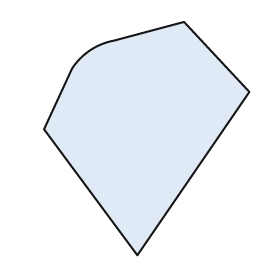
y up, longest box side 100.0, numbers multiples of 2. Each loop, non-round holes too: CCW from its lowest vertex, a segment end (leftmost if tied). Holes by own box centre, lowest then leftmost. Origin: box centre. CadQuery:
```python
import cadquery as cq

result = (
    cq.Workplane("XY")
    .moveTo(-4.0, -50.0)
    .lineTo(44.0, 20.0)
    .lineTo(16.0, 50.0)
    .lineTo(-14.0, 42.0)
    .threePointArc((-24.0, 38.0), (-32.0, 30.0))
    .lineTo(-44.0, 4.0)
    .close()
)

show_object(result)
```